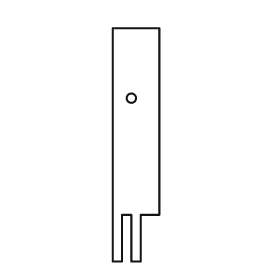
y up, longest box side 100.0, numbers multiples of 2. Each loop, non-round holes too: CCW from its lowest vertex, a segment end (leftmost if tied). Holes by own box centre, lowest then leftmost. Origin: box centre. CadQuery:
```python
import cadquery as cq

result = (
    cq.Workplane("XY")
    .moveTo(-10.0, -50.0)
    .lineTo(-6.0, -50.0)
    .lineTo(-6.0, -30.0)
    .lineTo(-2.0, -30.0)
    .lineTo(-2.0, -50.0)
    .lineTo(2.0, -50.0)
    .lineTo(2.0, -30.0)
    .lineTo(10.0, -30.0)
    .lineTo(10.0, 50.0)
    .lineTo(-10.0, 50.0)
    .close()
    .moveTo(-2.0, 20.0)
    .circle(2.0)
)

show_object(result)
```